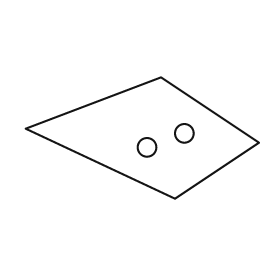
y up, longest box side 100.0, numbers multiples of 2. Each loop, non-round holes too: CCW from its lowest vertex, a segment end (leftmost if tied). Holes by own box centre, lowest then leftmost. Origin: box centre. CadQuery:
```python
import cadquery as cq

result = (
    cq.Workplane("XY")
    .moveTo(14.0, -26.0)
    .lineTo(50.0, -2.0)
    .lineTo(8.0, 26.0)
    .lineTo(-50.0, 4.0)
    .close()
    .moveTo(2.0, -4.0)
    .circle(4.0)
    .moveTo(18.0, 2.0)
    .circle(4.0)
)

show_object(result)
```